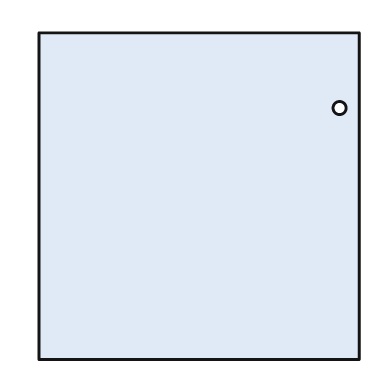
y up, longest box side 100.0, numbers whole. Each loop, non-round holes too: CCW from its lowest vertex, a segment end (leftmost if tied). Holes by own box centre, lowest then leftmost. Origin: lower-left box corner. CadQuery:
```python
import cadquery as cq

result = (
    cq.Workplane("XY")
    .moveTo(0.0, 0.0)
    .lineTo(98.0, 0.0)
    .lineTo(98.0, 100.0)
    .lineTo(0.0, 100.0)
    .close()
    .moveTo(92.0, 77.0)
    .circle(2.0)
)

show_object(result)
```